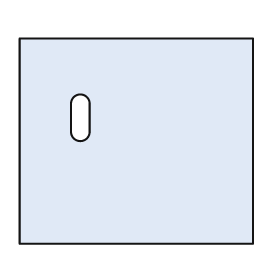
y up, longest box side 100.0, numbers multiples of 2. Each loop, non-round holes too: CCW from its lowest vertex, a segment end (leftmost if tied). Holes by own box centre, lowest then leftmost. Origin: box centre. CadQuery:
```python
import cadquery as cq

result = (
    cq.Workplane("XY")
    .moveTo(-50.0, -44.0)
    .lineTo(50.0, -44.0)
    .lineTo(50.0, 44.0)
    .lineTo(-50.0, 44.0)
    .close()
    .moveTo(-28.0, 4.0)
    .threePointArc((-24.0, 0.0), (-20.0, 4.0))
    .lineTo(-20.0, 16.0)
    .threePointArc((-24.0, 20.0), (-28.0, 16.0))
    .close()
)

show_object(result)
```